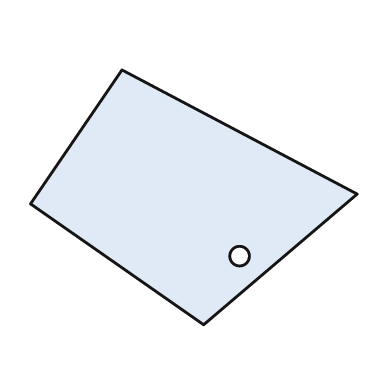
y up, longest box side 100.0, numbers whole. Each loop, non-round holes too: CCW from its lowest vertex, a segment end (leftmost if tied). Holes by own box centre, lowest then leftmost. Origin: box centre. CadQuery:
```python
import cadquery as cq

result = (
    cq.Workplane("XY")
    .moveTo(3.0, -39.0)
    .lineTo(50.0, 1.0)
    .lineTo(-22.0, 39.0)
    .lineTo(-50.0, -2.0)
    .close()
    .moveTo(14.0, -18.0)
    .circle(3.0)
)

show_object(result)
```